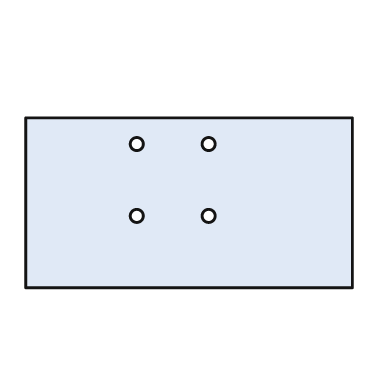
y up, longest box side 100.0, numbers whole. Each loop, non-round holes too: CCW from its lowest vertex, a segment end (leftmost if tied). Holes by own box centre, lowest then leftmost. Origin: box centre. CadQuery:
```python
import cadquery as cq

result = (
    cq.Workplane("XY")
    .moveTo(-50.0, -26.0)
    .lineTo(50.0, -26.0)
    .lineTo(50.0, 26.0)
    .lineTo(-50.0, 26.0)
    .close()
    .moveTo(-16.0, -4.0)
    .circle(2.0)
    .moveTo(6.0, -4.0)
    .circle(2.0)
    .moveTo(-16.0, 18.0)
    .circle(2.0)
    .moveTo(6.0, 18.0)
    .circle(2.0)
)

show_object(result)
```